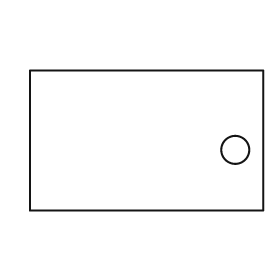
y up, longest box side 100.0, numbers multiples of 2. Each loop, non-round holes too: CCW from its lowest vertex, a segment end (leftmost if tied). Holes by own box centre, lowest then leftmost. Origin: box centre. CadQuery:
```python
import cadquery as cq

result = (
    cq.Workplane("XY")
    .moveTo(-50.0, -30.0)
    .lineTo(50.0, -30.0)
    .lineTo(50.0, 30.0)
    .lineTo(-50.0, 30.0)
    .close()
    .moveTo(38.0, -4.0)
    .circle(6.0)
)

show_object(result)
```